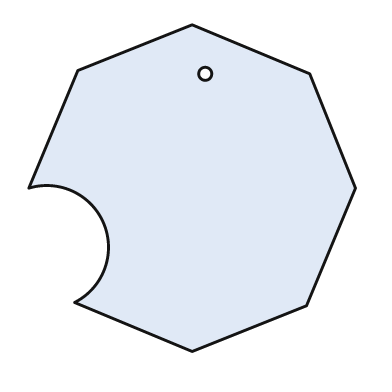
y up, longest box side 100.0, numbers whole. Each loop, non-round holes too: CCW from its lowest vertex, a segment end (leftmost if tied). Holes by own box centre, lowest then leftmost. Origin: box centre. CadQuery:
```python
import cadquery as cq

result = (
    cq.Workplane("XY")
    .moveTo(0.0, -50.0)
    .lineTo(35.0, -36.0)
    .lineTo(50.0, 0.0)
    .lineTo(36.0, 35.0)
    .lineTo(0.0, 50.0)
    .lineTo(-35.0, 36.0)
    .lineTo(-50.0, 0.0)
    .threePointArc((-27.0, -11.0), (-36.0, -35.0))
    .close()
    .moveTo(4.0, 35.0)
    .circle(2.0)
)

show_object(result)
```